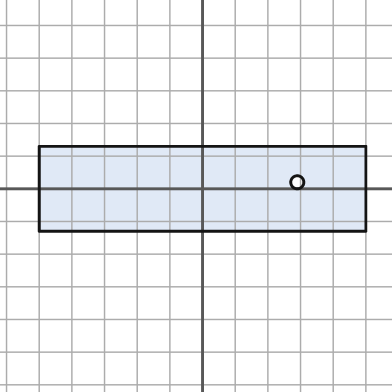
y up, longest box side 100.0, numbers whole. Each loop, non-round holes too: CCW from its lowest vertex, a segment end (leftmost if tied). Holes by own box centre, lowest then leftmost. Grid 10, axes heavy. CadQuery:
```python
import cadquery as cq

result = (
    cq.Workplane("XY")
    .moveTo(-50.0, -13.0)
    .lineTo(50.0, -13.0)
    .lineTo(50.0, 13.0)
    .lineTo(-50.0, 13.0)
    .close()
    .moveTo(29.0, 2.0)
    .circle(2.0)
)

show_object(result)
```